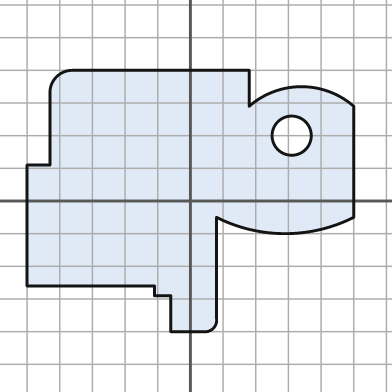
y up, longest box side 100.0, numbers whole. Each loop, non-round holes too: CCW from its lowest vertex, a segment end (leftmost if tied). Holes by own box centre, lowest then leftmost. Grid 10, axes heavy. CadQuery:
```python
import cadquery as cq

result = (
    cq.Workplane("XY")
    .moveTo(-6.0, -40.0)
    .lineTo(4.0, -40.0)
    .threePointArc((7.0, -39.0), (8.0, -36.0))
    .lineTo(8.0, -5.0)
    .threePointArc((29.0, -10.0), (50.0, -5.0))
    .lineTo(50.0, 29.0)
    .threePointArc((34.0, 35.0), (18.0, 29.0))
    .lineTo(18.0, 40.0)
    .lineTo(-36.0, 40.0)
    .threePointArc((-41.0, 38.0), (-43.0, 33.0))
    .lineTo(-43.0, 11.0)
    .lineTo(-50.0, 11.0)
    .lineTo(-50.0, -26.0)
    .lineTo(-11.0, -26.0)
    .lineTo(-11.0, -29.0)
    .lineTo(-6.0, -29.0)
    .close()
    .moveTo(31.0, 20.0)
    .circle(6.0)
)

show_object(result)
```